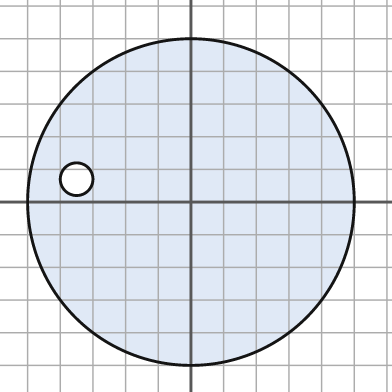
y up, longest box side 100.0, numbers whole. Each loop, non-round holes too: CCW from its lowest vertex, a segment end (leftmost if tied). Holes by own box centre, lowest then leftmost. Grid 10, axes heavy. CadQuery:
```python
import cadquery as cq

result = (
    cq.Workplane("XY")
    .moveTo(0.0, 0.0)
    .circle(50.0)
    .moveTo(-35.0, 7.0)
    .circle(5.0)
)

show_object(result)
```